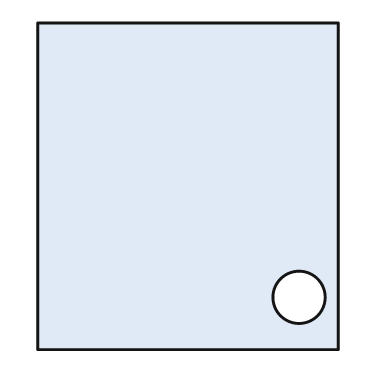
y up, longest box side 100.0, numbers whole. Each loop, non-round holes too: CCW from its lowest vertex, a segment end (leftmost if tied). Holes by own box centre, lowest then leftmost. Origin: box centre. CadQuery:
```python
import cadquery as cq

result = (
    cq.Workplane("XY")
    .moveTo(-46.0, -50.0)
    .lineTo(46.0, -50.0)
    .lineTo(46.0, 50.0)
    .lineTo(-46.0, 50.0)
    .close()
    .moveTo(34.0, -34.0)
    .circle(8.0)
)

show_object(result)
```